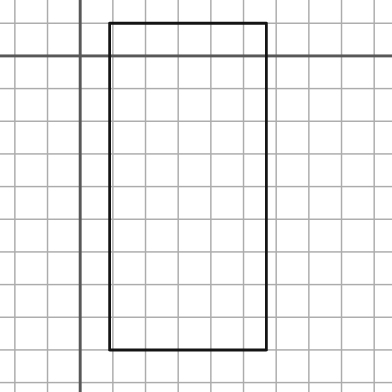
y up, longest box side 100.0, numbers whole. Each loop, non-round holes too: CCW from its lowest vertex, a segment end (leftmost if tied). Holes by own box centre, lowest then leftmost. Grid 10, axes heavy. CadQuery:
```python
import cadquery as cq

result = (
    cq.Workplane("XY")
    .moveTo(9.0, -90.0)
    .lineTo(57.0, -90.0)
    .lineTo(57.0, 10.0)
    .lineTo(9.0, 10.0)
    .close()
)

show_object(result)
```